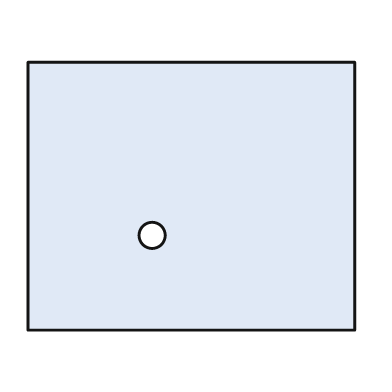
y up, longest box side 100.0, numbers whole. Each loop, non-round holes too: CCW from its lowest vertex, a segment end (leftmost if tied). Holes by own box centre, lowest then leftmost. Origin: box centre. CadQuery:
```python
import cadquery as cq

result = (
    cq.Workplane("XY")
    .moveTo(-50.0, -41.0)
    .lineTo(50.0, -41.0)
    .lineTo(50.0, 41.0)
    .lineTo(-50.0, 41.0)
    .close()
    .moveTo(-12.0, -12.0)
    .circle(4.0)
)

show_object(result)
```